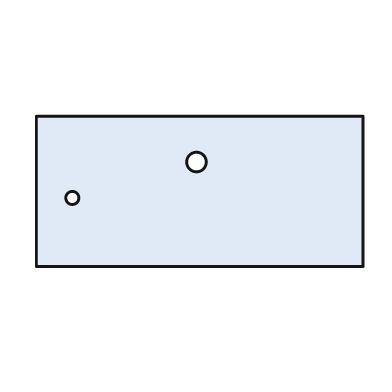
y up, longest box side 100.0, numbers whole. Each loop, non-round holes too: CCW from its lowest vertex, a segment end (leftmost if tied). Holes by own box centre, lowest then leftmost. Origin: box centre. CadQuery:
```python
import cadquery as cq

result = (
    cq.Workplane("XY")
    .moveTo(-50.0, -23.0)
    .lineTo(50.0, -23.0)
    .lineTo(50.0, 23.0)
    .lineTo(-50.0, 23.0)
    .close()
    .moveTo(-39.0, -2.0)
    .circle(2.0)
    .moveTo(-1.0, 9.0)
    .circle(3.0)
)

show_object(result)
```